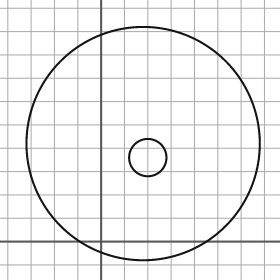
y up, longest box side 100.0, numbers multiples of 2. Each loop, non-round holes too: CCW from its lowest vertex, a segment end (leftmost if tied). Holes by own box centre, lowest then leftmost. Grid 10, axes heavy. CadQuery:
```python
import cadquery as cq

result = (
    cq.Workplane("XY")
    .moveTo(18.0, 42.0)
    .circle(50.0)
    .moveTo(20.0, 36.0)
    .circle(8.0)
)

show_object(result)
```